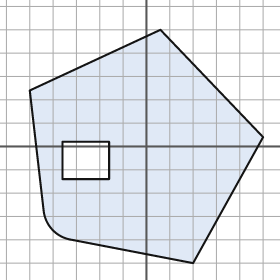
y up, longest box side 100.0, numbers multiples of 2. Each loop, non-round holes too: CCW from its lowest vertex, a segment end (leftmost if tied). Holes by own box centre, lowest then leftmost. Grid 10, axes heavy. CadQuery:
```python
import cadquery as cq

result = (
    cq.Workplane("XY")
    .moveTo(20.0, -50.0)
    .lineTo(50.0, 4.0)
    .lineTo(6.0, 50.0)
    .lineTo(-50.0, 24.0)
    .lineTo(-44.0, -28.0)
    .threePointArc((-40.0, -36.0), (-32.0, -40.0))
    .close()
    .moveTo(-36.0, -14.0)
    .lineTo(-16.0, -14.0)
    .lineTo(-16.0, 2.0)
    .lineTo(-36.0, 2.0)
    .close()
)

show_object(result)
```